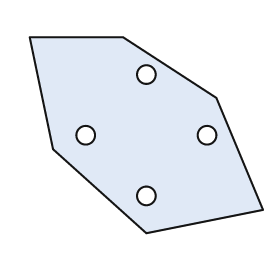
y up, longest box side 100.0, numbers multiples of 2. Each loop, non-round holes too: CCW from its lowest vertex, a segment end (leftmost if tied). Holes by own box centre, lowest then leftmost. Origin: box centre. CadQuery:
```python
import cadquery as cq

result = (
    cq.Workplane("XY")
    .moveTo(0.0, -42.0)
    .lineTo(50.0, -32.0)
    .lineTo(30.0, 16.0)
    .lineTo(-10.0, 42.0)
    .lineTo(-50.0, 42.0)
    .lineTo(-40.0, -6.0)
    .close()
    .moveTo(0.0, -26.0)
    .circle(4.0)
    .moveTo(-26.0, 0.0)
    .circle(4.0)
    .moveTo(26.0, 0.0)
    .circle(4.0)
    .moveTo(0.0, 26.0)
    .circle(4.0)
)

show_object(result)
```